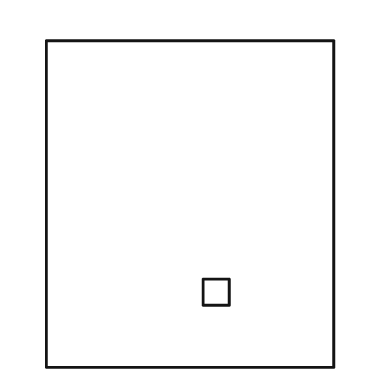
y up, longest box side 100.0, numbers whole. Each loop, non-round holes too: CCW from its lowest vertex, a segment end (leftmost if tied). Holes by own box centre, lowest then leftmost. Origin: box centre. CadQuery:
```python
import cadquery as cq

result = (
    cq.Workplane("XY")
    .moveTo(-44.0, -50.0)
    .lineTo(44.0, -50.0)
    .lineTo(44.0, 50.0)
    .lineTo(-44.0, 50.0)
    .close()
    .moveTo(4.0, -31.0)
    .lineTo(12.0, -31.0)
    .lineTo(12.0, -23.0)
    .lineTo(4.0, -23.0)
    .close()
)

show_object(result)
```